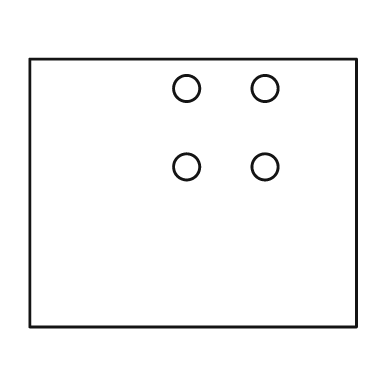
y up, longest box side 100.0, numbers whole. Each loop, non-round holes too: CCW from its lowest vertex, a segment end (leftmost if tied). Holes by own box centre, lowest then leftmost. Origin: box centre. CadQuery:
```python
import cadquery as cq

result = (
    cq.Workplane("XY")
    .moveTo(-50.0, -41.0)
    .lineTo(50.0, -41.0)
    .lineTo(50.0, 41.0)
    .lineTo(-50.0, 41.0)
    .close()
    .moveTo(-2.0, 8.0)
    .circle(4.0)
    .moveTo(22.0, 8.0)
    .circle(4.0)
    .moveTo(-2.0, 32.0)
    .circle(4.0)
    .moveTo(22.0, 32.0)
    .circle(4.0)
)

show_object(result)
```